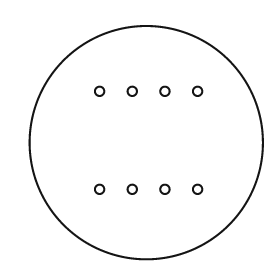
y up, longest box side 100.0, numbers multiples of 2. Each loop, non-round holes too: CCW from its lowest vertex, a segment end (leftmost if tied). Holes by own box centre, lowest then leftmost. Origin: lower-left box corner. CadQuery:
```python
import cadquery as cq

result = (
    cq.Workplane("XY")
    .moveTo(50.0, 50.0)
    .circle(50.0)
    .moveTo(30.0, 30.0)
    .circle(2.0)
    .moveTo(44.0, 30.0)
    .circle(2.0)
    .moveTo(58.0, 30.0)
    .circle(2.0)
    .moveTo(72.0, 30.0)
    .circle(2.0)
    .moveTo(30.0, 72.0)
    .circle(2.0)
    .moveTo(44.0, 72.0)
    .circle(2.0)
    .moveTo(58.0, 72.0)
    .circle(2.0)
    .moveTo(72.0, 72.0)
    .circle(2.0)
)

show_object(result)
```